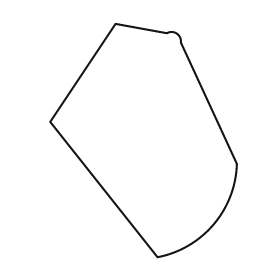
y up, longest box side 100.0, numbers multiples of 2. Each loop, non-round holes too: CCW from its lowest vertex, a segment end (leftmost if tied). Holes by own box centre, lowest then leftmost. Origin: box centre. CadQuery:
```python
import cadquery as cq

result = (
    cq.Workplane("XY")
    .moveTo(6.0, -50.0)
    .threePointArc((30.0, -36.0), (40.0, -10.0))
    .lineTo(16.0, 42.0)
    .threePointArc((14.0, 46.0), (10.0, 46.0))
    .lineTo(-12.0, 50.0)
    .lineTo(-40.0, 8.0)
    .close()
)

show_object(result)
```